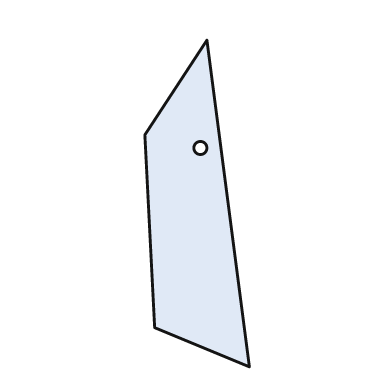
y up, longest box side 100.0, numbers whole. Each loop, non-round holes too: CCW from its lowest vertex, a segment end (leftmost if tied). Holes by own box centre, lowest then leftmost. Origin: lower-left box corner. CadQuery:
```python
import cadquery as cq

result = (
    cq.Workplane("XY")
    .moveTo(32.0, 0.0)
    .lineTo(19.0, 100.0)
    .lineTo(0.0, 71.0)
    .lineTo(3.0, 12.0)
    .close()
    .moveTo(17.0, 67.0)
    .circle(2.0)
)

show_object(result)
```